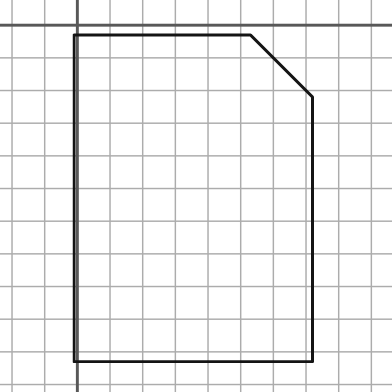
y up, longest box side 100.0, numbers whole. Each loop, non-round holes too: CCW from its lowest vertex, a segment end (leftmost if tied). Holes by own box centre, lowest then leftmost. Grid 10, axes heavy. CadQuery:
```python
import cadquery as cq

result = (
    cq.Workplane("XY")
    .moveTo(-1.0, -103.0)
    .lineTo(72.0, -103.0)
    .lineTo(72.0, -22.0)
    .lineTo(53.0, -3.0)
    .lineTo(-1.0, -3.0)
    .close()
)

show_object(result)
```